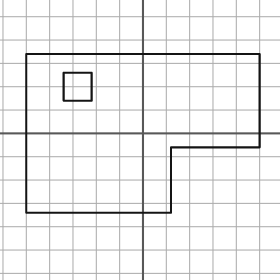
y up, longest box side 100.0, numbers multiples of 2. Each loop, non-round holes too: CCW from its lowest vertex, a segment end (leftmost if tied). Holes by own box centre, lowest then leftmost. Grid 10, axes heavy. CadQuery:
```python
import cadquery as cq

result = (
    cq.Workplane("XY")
    .moveTo(-50.0, -34.0)
    .lineTo(12.0, -34.0)
    .lineTo(12.0, -6.0)
    .lineTo(50.0, -6.0)
    .lineTo(50.0, 34.0)
    .lineTo(-50.0, 34.0)
    .close()
    .moveTo(-34.0, 14.0)
    .lineTo(-22.0, 14.0)
    .lineTo(-22.0, 26.0)
    .lineTo(-34.0, 26.0)
    .close()
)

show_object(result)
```